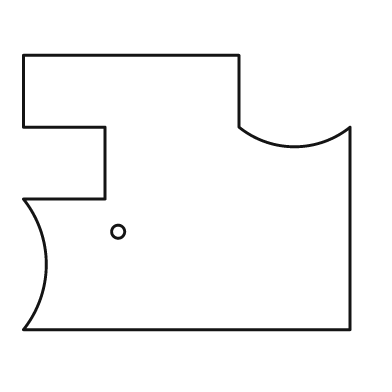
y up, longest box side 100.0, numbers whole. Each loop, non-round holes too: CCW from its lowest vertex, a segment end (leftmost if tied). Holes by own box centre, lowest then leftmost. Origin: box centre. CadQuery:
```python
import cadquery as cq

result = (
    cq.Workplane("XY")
    .moveTo(-50.0, -42.0)
    .lineTo(50.0, -42.0)
    .lineTo(50.0, 20.0)
    .threePointArc((33.0, 14.0), (16.0, 20.0))
    .lineTo(16.0, 42.0)
    .lineTo(-50.0, 42.0)
    .lineTo(-50.0, 20.0)
    .lineTo(-25.0, 20.0)
    .lineTo(-25.0, -2.0)
    .lineTo(-50.0, -2.0)
    .threePointArc((-43.0, -22.0), (-50.0, -42.0))
    .close()
    .moveTo(-21.0, -12.0)
    .circle(2.0)
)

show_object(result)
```